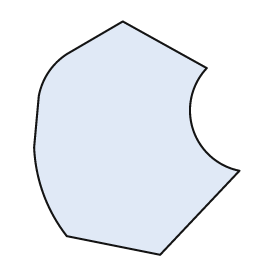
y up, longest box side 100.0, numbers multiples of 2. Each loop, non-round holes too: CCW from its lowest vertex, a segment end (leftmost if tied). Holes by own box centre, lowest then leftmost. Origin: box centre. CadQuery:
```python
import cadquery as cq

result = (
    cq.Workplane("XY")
    .moveTo(10.0, -50.0)
    .lineTo(44.0, -14.0)
    .threePointArc((24.0, 4.0), (30.0, 30.0))
    .lineTo(-6.0, 50.0)
    .lineTo(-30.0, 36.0)
    .threePointArc((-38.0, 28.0), (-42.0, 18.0))
    .lineTo(-44.0, -4.0)
    .threePointArc((-40.0, -24.0), (-30.0, -42.0))
    .close()
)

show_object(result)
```